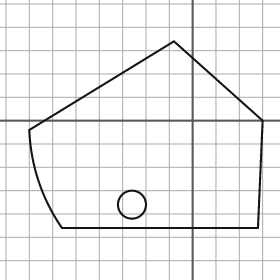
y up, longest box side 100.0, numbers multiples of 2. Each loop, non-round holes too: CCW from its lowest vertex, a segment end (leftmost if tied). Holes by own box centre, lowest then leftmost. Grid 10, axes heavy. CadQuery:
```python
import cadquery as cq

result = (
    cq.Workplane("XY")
    .moveTo(-56.0, -46.0)
    .lineTo(28.0, -46.0)
    .lineTo(30.0, 0.0)
    .lineTo(-8.0, 34.0)
    .lineTo(-70.0, -4.0)
    .threePointArc((-66.0, -26.0), (-56.0, -46.0))
    .close()
    .moveTo(-26.0, -36.0)
    .circle(6.0)
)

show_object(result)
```